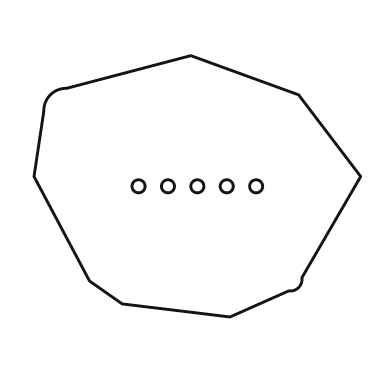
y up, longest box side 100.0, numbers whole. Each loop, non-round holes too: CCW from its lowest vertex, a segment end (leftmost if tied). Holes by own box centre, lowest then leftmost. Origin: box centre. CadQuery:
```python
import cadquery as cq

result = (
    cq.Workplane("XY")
    .moveTo(10.0, -40.0)
    .lineTo(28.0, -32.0)
    .threePointArc((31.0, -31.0), (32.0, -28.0))
    .lineTo(50.0, 3.0)
    .lineTo(31.0, 28.0)
    .lineTo(-2.0, 40.0)
    .lineTo(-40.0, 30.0)
    .threePointArc((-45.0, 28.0), (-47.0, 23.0))
    .lineTo(-50.0, 3.0)
    .lineTo(-33.0, -29.0)
    .lineTo(-23.0, -36.0)
    .close()
    .moveTo(-18.0, 0.0)
    .circle(2.0)
    .moveTo(-9.0, 0.0)
    .circle(2.0)
    .moveTo(0.0, 0.0)
    .circle(2.0)
    .moveTo(9.0, 0.0)
    .circle(2.0)
    .moveTo(18.0, 0.0)
    .circle(2.0)
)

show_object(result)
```